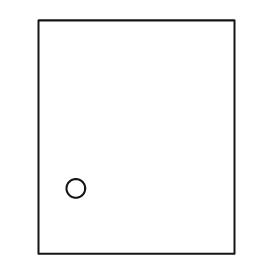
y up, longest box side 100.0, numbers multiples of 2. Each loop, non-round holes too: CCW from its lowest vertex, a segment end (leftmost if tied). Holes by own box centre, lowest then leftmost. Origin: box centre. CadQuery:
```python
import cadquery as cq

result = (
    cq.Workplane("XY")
    .moveTo(-42.0, -50.0)
    .lineTo(42.0, -50.0)
    .lineTo(42.0, 50.0)
    .lineTo(-42.0, 50.0)
    .close()
    .moveTo(-26.0, -22.0)
    .circle(4.0)
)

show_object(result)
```